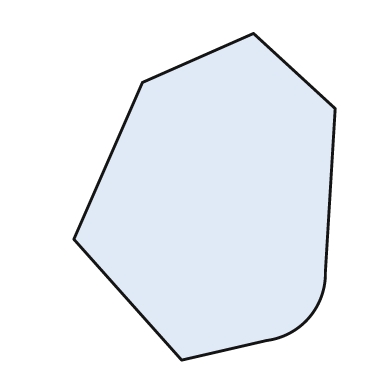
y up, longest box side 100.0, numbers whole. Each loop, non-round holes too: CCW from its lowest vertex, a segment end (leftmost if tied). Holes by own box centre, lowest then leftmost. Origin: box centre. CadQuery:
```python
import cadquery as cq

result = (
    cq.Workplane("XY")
    .moveTo(-7.0, -50.0)
    .lineTo(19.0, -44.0)
    .threePointArc((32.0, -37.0), (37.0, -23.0))
    .lineTo(40.0, 27.0)
    .lineTo(15.0, 50.0)
    .lineTo(-19.0, 35.0)
    .lineTo(-40.0, -13.0)
    .close()
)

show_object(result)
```